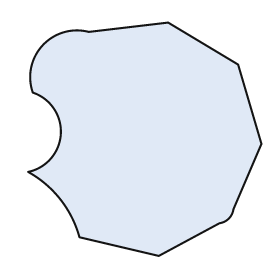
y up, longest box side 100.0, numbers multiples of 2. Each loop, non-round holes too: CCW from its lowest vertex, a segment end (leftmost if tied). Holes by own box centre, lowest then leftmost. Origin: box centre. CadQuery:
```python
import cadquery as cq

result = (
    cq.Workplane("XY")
    .moveTo(6.0, -50.0)
    .lineTo(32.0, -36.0)
    .threePointArc((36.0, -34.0), (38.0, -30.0))
    .lineTo(50.0, -2.0)
    .lineTo(40.0, 32.0)
    .lineTo(10.0, 50.0)
    .lineTo(-24.0, 46.0)
    .threePointArc((-44.0, 40.0), (-48.0, 20.0))
    .threePointArc((-36.0, 2.0), (-50.0, -14.0))
    .threePointArc((-36.0, -26.0), (-28.0, -42.0))
    .close()
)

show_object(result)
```